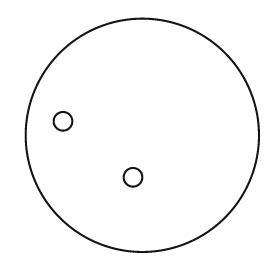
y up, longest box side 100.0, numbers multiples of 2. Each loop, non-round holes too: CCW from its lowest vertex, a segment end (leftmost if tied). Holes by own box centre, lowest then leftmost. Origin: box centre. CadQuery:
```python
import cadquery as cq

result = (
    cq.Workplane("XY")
    .moveTo(0.0, 0.0)
    .circle(50.0)
    .moveTo(-4.0, -18.0)
    .circle(4.0)
    .moveTo(-34.0, 6.0)
    .circle(4.0)
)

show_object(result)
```